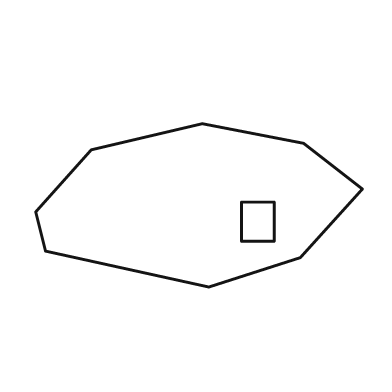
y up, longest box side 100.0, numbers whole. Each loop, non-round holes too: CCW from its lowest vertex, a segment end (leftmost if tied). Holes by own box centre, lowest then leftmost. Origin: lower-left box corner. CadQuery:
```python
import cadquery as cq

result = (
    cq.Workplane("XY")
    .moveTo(53.0, 0.0)
    .lineTo(81.0, 9.0)
    .lineTo(100.0, 30.0)
    .lineTo(82.0, 44.0)
    .lineTo(51.0, 50.0)
    .lineTo(17.0, 42.0)
    .lineTo(0.0, 23.0)
    .lineTo(3.0, 11.0)
    .close()
    .moveTo(63.0, 14.0)
    .lineTo(73.0, 14.0)
    .lineTo(73.0, 26.0)
    .lineTo(63.0, 26.0)
    .close()
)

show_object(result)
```